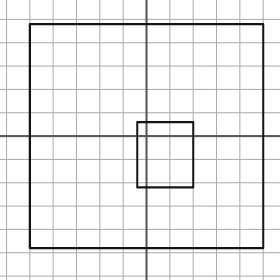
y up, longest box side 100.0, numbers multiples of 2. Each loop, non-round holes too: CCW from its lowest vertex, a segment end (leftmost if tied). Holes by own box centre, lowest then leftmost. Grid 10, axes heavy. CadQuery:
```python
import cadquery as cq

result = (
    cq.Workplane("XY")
    .moveTo(-50.0, -48.0)
    .lineTo(50.0, -48.0)
    .lineTo(50.0, 48.0)
    .lineTo(-50.0, 48.0)
    .close()
    .moveTo(-4.0, -22.0)
    .lineTo(20.0, -22.0)
    .lineTo(20.0, 6.0)
    .lineTo(-4.0, 6.0)
    .close()
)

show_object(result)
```